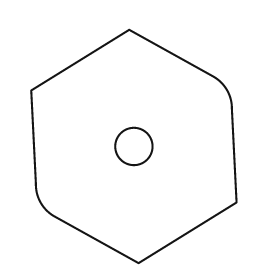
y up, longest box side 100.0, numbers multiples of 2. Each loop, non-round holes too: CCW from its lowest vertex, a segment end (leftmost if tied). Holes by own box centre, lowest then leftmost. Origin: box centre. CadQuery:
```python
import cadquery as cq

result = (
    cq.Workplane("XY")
    .moveTo(2.0, -50.0)
    .lineTo(44.0, -24.0)
    .lineTo(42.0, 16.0)
    .threePointArc((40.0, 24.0), (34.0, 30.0))
    .lineTo(-2.0, 50.0)
    .lineTo(-44.0, 24.0)
    .lineTo(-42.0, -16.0)
    .threePointArc((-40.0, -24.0), (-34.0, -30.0))
    .close()
    .moveTo(0.0, 0.0)
    .circle(8.0)
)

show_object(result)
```